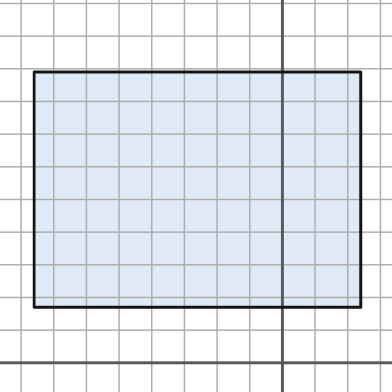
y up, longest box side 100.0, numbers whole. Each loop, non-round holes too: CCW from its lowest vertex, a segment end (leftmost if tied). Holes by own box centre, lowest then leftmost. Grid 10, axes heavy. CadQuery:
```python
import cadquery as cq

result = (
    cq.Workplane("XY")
    .moveTo(-76.0, 17.0)
    .lineTo(24.0, 17.0)
    .lineTo(24.0, 89.0)
    .lineTo(-76.0, 89.0)
    .close()
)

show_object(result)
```